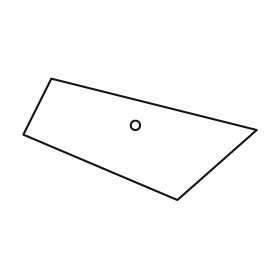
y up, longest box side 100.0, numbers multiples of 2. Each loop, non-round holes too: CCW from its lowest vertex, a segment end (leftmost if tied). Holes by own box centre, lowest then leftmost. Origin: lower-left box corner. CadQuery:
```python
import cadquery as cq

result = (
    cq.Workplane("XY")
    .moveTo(66.0, 0.0)
    .lineTo(100.0, 30.0)
    .lineTo(12.0, 52.0)
    .lineTo(0.0, 28.0)
    .close()
    .moveTo(48.0, 32.0)
    .circle(2.0)
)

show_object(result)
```